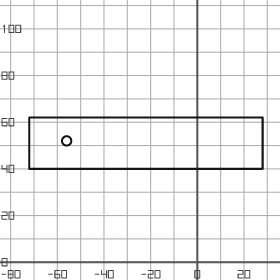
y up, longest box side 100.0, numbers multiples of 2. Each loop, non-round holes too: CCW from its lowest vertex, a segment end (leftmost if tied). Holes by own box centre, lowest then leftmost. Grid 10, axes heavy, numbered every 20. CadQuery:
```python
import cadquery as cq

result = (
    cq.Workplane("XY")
    .moveTo(-72.0, 40.0)
    .lineTo(28.0, 40.0)
    .lineTo(28.0, 62.0)
    .lineTo(-72.0, 62.0)
    .close()
    .moveTo(-56.0, 52.0)
    .circle(2.0)
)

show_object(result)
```